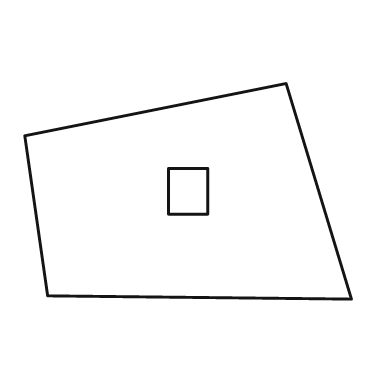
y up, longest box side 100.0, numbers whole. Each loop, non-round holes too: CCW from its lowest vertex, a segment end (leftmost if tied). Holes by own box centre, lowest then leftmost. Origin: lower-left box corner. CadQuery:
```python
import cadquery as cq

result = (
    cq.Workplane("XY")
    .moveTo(100.0, 0.0)
    .lineTo(80.0, 66.0)
    .lineTo(0.0, 50.0)
    .lineTo(7.0, 1.0)
    .close()
    .moveTo(44.0, 26.0)
    .lineTo(56.0, 26.0)
    .lineTo(56.0, 40.0)
    .lineTo(44.0, 40.0)
    .close()
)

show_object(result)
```